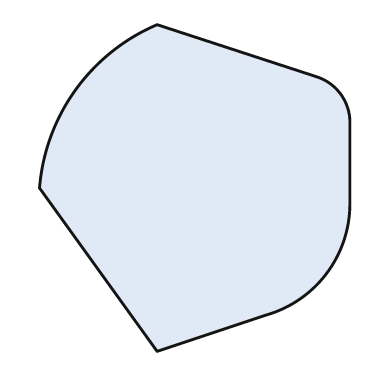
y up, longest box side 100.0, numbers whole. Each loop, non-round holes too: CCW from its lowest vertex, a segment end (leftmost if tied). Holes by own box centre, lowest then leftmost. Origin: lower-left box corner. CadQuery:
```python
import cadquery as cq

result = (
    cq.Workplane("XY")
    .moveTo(36.0, 0.0)
    .lineTo(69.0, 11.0)
    .threePointArc((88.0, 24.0), (95.0, 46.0))
    .lineTo(95.0, 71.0)
    .threePointArc((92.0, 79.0), (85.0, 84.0))
    .lineTo(36.0, 100.0)
    .threePointArc((11.0, 80.0), (0.0, 50.0))
    .close()
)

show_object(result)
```